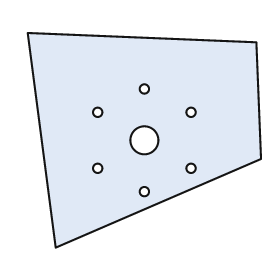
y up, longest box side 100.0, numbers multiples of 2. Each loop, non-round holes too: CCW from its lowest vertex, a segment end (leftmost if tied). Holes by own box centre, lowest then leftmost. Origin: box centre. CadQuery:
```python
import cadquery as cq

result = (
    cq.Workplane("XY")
    .moveTo(-38.0, -46.0)
    .lineTo(50.0, -8.0)
    .lineTo(48.0, 42.0)
    .lineTo(-50.0, 46.0)
    .close()
    .moveTo(0.0, -22.0)
    .circle(2.0)
    .moveTo(-20.0, -12.0)
    .circle(2.0)
    .moveTo(20.0, -12.0)
    .circle(2.0)
    .moveTo(0.0, 0.0)
    .circle(6.0)
    .moveTo(-20.0, 12.0)
    .circle(2.0)
    .moveTo(20.0, 12.0)
    .circle(2.0)
    .moveTo(0.0, 22.0)
    .circle(2.0)
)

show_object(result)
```